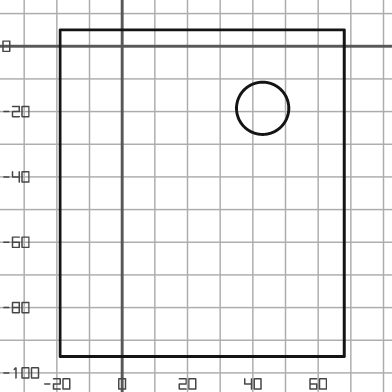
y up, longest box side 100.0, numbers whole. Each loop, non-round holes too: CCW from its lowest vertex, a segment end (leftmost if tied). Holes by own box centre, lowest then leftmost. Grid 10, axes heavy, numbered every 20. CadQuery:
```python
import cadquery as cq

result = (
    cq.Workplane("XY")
    .moveTo(-19.0, -95.0)
    .lineTo(68.0, -95.0)
    .lineTo(68.0, 5.0)
    .lineTo(-19.0, 5.0)
    .close()
    .moveTo(43.0, -19.0)
    .circle(8.0)
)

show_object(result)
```